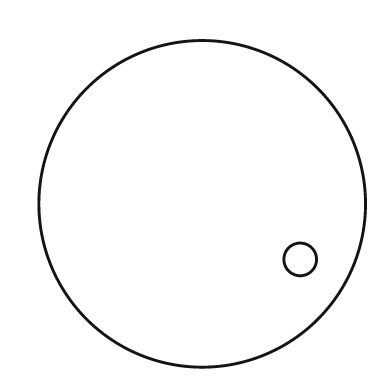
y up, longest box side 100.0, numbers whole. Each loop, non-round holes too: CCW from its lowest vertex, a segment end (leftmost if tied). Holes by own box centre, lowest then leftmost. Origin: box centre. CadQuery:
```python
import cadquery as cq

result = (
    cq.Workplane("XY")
    .moveTo(0.0, 0.0)
    .circle(50.0)
    .moveTo(30.0, -17.0)
    .circle(5.0)
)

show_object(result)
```